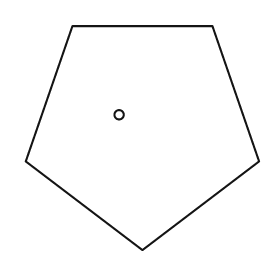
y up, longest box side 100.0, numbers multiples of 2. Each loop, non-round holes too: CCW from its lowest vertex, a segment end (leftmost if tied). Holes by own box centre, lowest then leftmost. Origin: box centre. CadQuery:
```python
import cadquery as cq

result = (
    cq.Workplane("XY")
    .moveTo(0.0, -48.0)
    .lineTo(50.0, -10.0)
    .lineTo(30.0, 48.0)
    .lineTo(-30.0, 48.0)
    .lineTo(-50.0, -10.0)
    .close()
    .moveTo(-10.0, 10.0)
    .circle(2.0)
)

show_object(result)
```